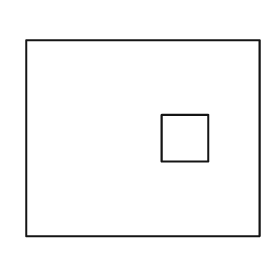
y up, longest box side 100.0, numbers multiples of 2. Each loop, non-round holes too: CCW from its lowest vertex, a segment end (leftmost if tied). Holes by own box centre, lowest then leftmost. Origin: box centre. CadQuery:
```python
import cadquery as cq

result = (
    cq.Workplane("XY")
    .moveTo(-50.0, -42.0)
    .lineTo(50.0, -42.0)
    .lineTo(50.0, 42.0)
    .lineTo(-50.0, 42.0)
    .close()
    .moveTo(8.0, -10.0)
    .lineTo(28.0, -10.0)
    .lineTo(28.0, 10.0)
    .lineTo(8.0, 10.0)
    .close()
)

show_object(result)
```